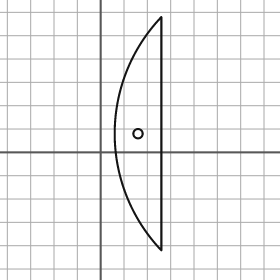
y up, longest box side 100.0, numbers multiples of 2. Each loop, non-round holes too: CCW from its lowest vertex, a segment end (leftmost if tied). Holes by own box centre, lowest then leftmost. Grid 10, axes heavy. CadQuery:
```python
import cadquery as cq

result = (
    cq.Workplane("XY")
    .moveTo(26.0, -42.0)
    .lineTo(26.0, 58.0)
    .threePointArc((6.0, 8.0), (26.0, -42.0))
    .close()
    .moveTo(16.0, 8.0)
    .circle(2.0)
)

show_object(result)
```